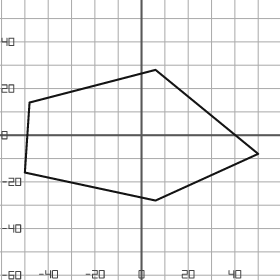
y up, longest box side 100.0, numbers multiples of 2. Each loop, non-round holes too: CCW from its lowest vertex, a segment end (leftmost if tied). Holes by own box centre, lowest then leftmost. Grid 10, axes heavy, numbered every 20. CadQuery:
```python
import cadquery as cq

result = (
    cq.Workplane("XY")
    .moveTo(6.0, -28.0)
    .lineTo(50.0, -8.0)
    .lineTo(6.0, 28.0)
    .lineTo(-48.0, 14.0)
    .lineTo(-50.0, -16.0)
    .close()
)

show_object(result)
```